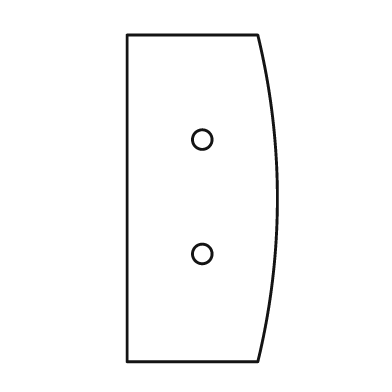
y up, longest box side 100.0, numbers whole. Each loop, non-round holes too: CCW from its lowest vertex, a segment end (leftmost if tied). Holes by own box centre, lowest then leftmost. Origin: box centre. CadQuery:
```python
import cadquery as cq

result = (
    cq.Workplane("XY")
    .moveTo(-23.0, -50.0)
    .lineTo(17.0, -50.0)
    .threePointArc((23.0, 0.0), (17.0, 50.0))
    .lineTo(-23.0, 50.0)
    .close()
    .moveTo(0.0, -17.0)
    .circle(3.0)
    .moveTo(0.0, 18.0)
    .circle(3.0)
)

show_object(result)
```